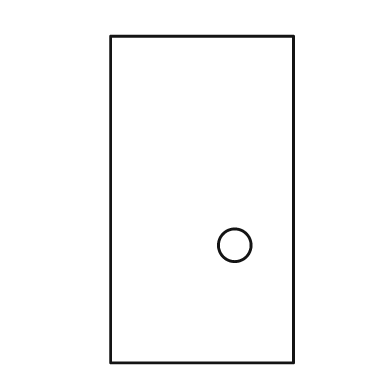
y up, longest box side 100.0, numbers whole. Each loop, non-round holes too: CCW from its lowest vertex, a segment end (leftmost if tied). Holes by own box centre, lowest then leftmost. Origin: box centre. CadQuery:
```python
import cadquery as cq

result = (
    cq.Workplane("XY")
    .moveTo(-28.0, -50.0)
    .lineTo(28.0, -50.0)
    .lineTo(28.0, 50.0)
    .lineTo(-28.0, 50.0)
    .close()
    .moveTo(10.0, -14.0)
    .circle(5.0)
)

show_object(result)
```